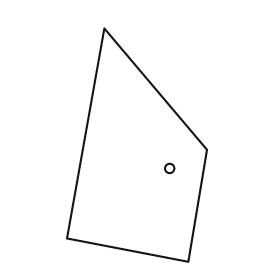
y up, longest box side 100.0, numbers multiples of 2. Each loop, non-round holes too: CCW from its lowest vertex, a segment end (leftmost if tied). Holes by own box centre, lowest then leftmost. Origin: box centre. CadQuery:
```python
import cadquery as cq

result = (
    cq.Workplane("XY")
    .moveTo(22.0, -50.0)
    .lineTo(30.0, -2.0)
    .lineTo(-14.0, 50.0)
    .lineTo(-30.0, -40.0)
    .close()
    .moveTo(14.0, -10.0)
    .circle(2.0)
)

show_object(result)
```